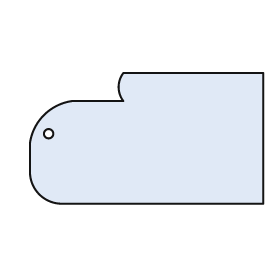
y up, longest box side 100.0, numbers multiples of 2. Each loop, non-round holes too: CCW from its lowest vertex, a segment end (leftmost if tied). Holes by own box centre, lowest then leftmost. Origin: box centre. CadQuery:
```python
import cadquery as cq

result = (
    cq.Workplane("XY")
    .moveTo(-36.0, -28.0)
    .lineTo(50.0, -28.0)
    .lineTo(50.0, 28.0)
    .lineTo(-10.0, 28.0)
    .threePointArc((-12.0, 22.0), (-10.0, 16.0))
    .lineTo(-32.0, 16.0)
    .threePointArc((-44.0, 10.0), (-50.0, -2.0))
    .lineTo(-50.0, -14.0)
    .threePointArc((-46.0, -24.0), (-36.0, -28.0))
    .close()
    .moveTo(-42.0, 2.0)
    .circle(2.0)
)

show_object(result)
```